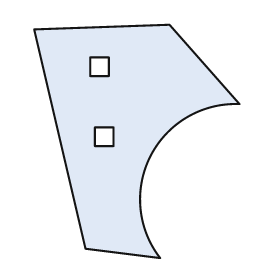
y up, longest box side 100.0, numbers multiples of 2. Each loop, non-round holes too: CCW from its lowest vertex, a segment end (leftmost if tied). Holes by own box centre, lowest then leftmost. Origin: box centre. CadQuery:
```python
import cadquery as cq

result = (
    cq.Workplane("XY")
    .moveTo(10.0, -50.0)
    .threePointArc((6.0, -6.0), (44.0, 16.0))
    .lineTo(14.0, 50.0)
    .lineTo(-44.0, 48.0)
    .lineTo(-22.0, -46.0)
    .close()
    .moveTo(-18.0, -2.0)
    .lineTo(-10.0, -2.0)
    .lineTo(-10.0, 6.0)
    .lineTo(-18.0, 6.0)
    .close()
    .moveTo(-20.0, 28.0)
    .lineTo(-12.0, 28.0)
    .lineTo(-12.0, 36.0)
    .lineTo(-20.0, 36.0)
    .close()
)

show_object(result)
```